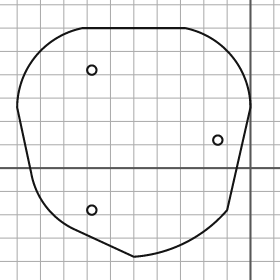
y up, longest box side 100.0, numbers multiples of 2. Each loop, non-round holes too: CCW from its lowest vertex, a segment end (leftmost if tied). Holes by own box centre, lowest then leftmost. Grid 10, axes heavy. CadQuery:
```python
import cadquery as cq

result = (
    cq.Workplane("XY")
    .moveTo(-50.0, -38.0)
    .threePointArc((-28.0, -32.0), (-10.0, -18.0))
    .lineTo(0.0, 26.0)
    .threePointArc((-8.0, 48.0), (-28.0, 60.0))
    .lineTo(-72.0, 60.0)
    .threePointArc((-92.0, 48.0), (-100.0, 26.0))
    .lineTo(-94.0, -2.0)
    .threePointArc((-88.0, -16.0), (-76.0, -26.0))
    .close()
    .moveTo(-68.0, -18.0)
    .circle(2.0)
    .moveTo(-14.0, 12.0)
    .circle(2.0)
    .moveTo(-68.0, 42.0)
    .circle(2.0)
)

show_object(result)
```